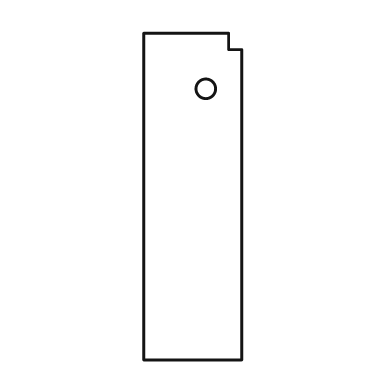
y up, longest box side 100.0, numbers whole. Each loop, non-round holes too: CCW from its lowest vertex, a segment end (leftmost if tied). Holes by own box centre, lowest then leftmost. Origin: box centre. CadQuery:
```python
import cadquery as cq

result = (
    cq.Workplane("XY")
    .moveTo(-15.0, -50.0)
    .lineTo(15.0, -50.0)
    .lineTo(15.0, 45.0)
    .lineTo(11.0, 45.0)
    .lineTo(11.0, 50.0)
    .lineTo(-15.0, 50.0)
    .close()
    .moveTo(4.0, 33.0)
    .circle(3.0)
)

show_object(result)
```